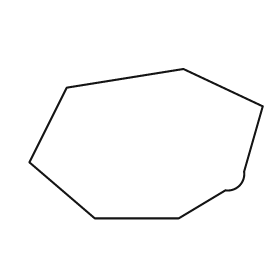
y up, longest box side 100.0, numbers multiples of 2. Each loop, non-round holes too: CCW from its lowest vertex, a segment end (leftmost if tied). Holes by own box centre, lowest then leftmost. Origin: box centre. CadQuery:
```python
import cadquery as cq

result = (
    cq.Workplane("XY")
    .moveTo(-22.0, -32.0)
    .lineTo(14.0, -32.0)
    .lineTo(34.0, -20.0)
    .threePointArc((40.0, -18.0), (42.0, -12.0))
    .lineTo(50.0, 16.0)
    .lineTo(16.0, 32.0)
    .lineTo(-34.0, 24.0)
    .lineTo(-50.0, -8.0)
    .close()
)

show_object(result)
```